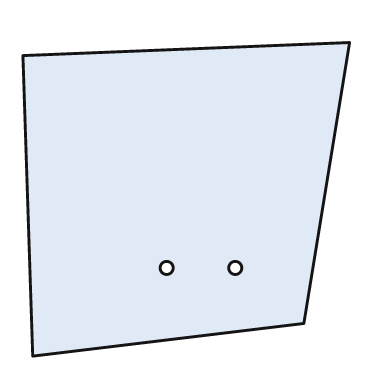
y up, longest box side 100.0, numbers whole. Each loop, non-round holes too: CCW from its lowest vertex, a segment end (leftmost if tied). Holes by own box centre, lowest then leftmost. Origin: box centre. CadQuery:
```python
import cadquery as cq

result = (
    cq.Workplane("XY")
    .moveTo(-47.0, -48.0)
    .lineTo(36.0, -38.0)
    .lineTo(50.0, 48.0)
    .lineTo(-50.0, 44.0)
    .close()
    .moveTo(-6.0, -21.0)
    .circle(2.0)
    .moveTo(15.0, -21.0)
    .circle(2.0)
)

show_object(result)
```